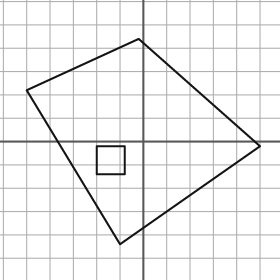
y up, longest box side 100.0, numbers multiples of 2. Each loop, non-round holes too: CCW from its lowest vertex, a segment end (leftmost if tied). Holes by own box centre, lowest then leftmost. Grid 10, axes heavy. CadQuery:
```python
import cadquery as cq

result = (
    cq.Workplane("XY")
    .moveTo(-10.0, -44.0)
    .lineTo(50.0, -2.0)
    .lineTo(-2.0, 44.0)
    .lineTo(-50.0, 22.0)
    .close()
    .moveTo(-20.0, -14.0)
    .lineTo(-8.0, -14.0)
    .lineTo(-8.0, -2.0)
    .lineTo(-20.0, -2.0)
    .close()
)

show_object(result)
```